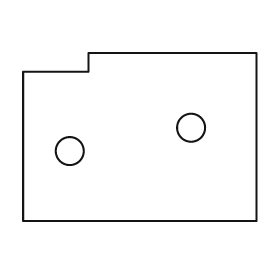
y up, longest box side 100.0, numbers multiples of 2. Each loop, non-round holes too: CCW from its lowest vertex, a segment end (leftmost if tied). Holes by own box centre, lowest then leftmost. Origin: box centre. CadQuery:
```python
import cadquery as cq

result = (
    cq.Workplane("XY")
    .moveTo(-50.0, -36.0)
    .lineTo(50.0, -36.0)
    .lineTo(50.0, 36.0)
    .lineTo(-22.0, 36.0)
    .lineTo(-22.0, 28.0)
    .lineTo(-50.0, 28.0)
    .close()
    .moveTo(-30.0, -6.0)
    .circle(6.0)
    .moveTo(22.0, 4.0)
    .circle(6.0)
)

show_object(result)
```